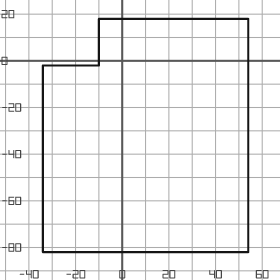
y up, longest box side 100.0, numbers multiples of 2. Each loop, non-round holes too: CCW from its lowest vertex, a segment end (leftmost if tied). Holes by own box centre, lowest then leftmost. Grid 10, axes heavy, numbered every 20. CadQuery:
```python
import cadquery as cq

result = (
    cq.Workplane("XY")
    .moveTo(-34.0, -82.0)
    .lineTo(54.0, -82.0)
    .lineTo(54.0, 18.0)
    .lineTo(-10.0, 18.0)
    .lineTo(-10.0, -2.0)
    .lineTo(-34.0, -2.0)
    .close()
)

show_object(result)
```